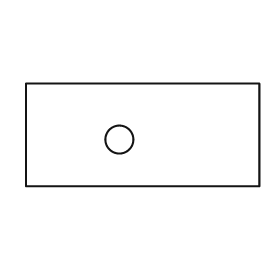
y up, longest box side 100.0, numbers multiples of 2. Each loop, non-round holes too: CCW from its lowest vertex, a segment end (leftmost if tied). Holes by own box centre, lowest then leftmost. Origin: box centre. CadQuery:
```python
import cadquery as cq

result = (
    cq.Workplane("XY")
    .moveTo(-50.0, -22.0)
    .lineTo(50.0, -22.0)
    .lineTo(50.0, 22.0)
    .lineTo(-50.0, 22.0)
    .close()
    .moveTo(-10.0, -2.0)
    .circle(6.0)
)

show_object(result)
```